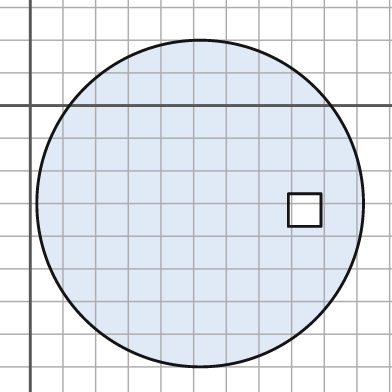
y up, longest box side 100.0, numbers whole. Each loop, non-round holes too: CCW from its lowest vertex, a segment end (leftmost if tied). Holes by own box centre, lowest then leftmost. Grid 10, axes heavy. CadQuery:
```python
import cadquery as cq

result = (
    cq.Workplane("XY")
    .moveTo(52.0, -30.0)
    .circle(50.0)
    .moveTo(79.0, -37.0)
    .lineTo(89.0, -37.0)
    .lineTo(89.0, -27.0)
    .lineTo(79.0, -27.0)
    .close()
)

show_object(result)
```